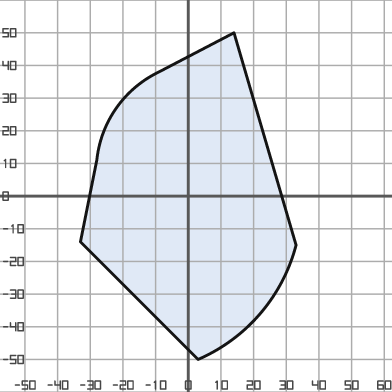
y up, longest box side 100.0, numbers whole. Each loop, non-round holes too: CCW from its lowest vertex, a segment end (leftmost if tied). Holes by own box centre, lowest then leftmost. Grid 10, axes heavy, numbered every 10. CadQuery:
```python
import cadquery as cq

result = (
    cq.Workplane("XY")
    .moveTo(3.0, -50.0)
    .threePointArc((22.0, -36.0), (33.0, -15.0))
    .lineTo(14.0, 50.0)
    .lineTo(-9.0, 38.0)
    .threePointArc((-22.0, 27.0), (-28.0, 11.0))
    .lineTo(-33.0, -14.0)
    .close()
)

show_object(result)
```